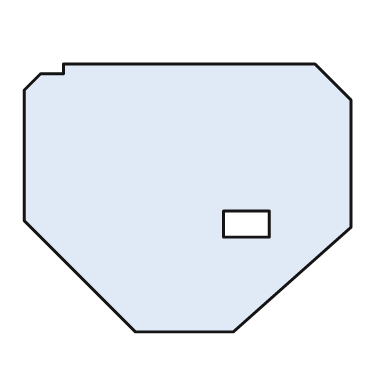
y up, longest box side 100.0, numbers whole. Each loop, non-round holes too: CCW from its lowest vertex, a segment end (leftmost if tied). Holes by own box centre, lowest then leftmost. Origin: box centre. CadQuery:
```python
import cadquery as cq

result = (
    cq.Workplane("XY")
    .moveTo(-16.0, -41.0)
    .lineTo(14.0, -41.0)
    .lineTo(50.0, -9.0)
    .lineTo(50.0, 30.0)
    .lineTo(39.0, 41.0)
    .lineTo(-38.0, 41.0)
    .lineTo(-38.0, 38.0)
    .lineTo(-45.0, 38.0)
    .lineTo(-50.0, 33.0)
    .lineTo(-50.0, -7.0)
    .close()
    .moveTo(11.0, -12.0)
    .lineTo(25.0, -12.0)
    .lineTo(25.0, -4.0)
    .lineTo(11.0, -4.0)
    .close()
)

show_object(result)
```